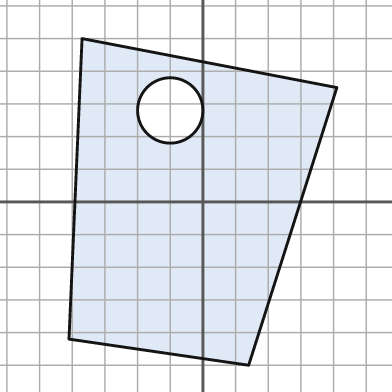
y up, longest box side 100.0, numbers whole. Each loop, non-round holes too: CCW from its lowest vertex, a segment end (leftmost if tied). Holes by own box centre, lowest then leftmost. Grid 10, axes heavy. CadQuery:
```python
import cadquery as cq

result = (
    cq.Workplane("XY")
    .moveTo(14.0, -50.0)
    .lineTo(41.0, 35.0)
    .lineTo(-37.0, 50.0)
    .lineTo(-41.0, -42.0)
    .close()
    .moveTo(-10.0, 28.0)
    .circle(10.0)
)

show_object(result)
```